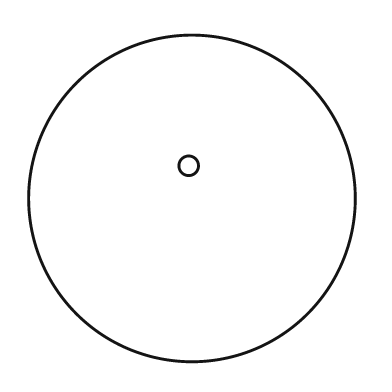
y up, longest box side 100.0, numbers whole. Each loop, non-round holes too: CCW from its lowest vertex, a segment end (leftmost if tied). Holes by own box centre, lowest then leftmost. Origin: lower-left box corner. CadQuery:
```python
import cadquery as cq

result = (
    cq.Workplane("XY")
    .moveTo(50.0, 50.0)
    .circle(50.0)
    .moveTo(49.0, 60.0)
    .circle(3.0)
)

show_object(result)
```